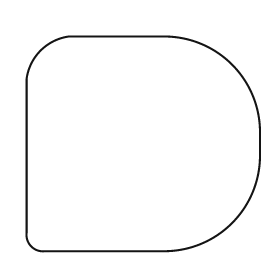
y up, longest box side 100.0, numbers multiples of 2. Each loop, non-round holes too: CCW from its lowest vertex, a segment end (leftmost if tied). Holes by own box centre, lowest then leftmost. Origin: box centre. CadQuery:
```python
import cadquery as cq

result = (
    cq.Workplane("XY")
    .moveTo(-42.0, -46.0)
    .lineTo(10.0, -46.0)
    .threePointArc((38.0, -34.0), (50.0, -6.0))
    .lineTo(50.0, 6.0)
    .threePointArc((38.0, 34.0), (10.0, 46.0))
    .lineTo(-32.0, 46.0)
    .threePointArc((-44.0, 40.0), (-50.0, 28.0))
    .lineTo(-50.0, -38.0)
    .threePointArc((-48.0, -44.0), (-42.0, -46.0))
    .close()
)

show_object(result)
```